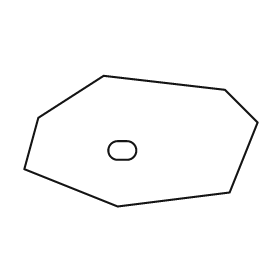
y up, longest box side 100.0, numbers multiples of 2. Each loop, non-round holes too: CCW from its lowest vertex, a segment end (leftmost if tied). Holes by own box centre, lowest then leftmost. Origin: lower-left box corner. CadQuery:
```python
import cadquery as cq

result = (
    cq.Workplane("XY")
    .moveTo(40.0, 0.0)
    .lineTo(88.0, 6.0)
    .lineTo(100.0, 36.0)
    .lineTo(86.0, 50.0)
    .lineTo(34.0, 56.0)
    .lineTo(6.0, 38.0)
    .lineTo(0.0, 16.0)
    .close()
    .moveTo(40.0, 20.0)
    .lineTo(44.0, 20.0)
    .threePointArc((48.0, 24.0), (44.0, 28.0))
    .lineTo(40.0, 28.0)
    .threePointArc((36.0, 24.0), (40.0, 20.0))
    .close()
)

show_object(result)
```